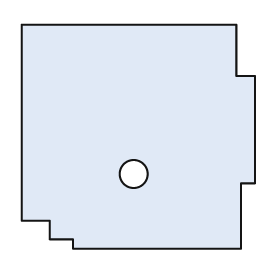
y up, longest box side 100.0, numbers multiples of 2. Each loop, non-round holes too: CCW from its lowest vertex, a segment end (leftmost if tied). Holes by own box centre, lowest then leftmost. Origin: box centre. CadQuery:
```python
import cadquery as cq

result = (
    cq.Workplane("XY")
    .moveTo(-28.0, -48.0)
    .lineTo(44.0, -48.0)
    .lineTo(44.0, -20.0)
    .lineTo(50.0, -20.0)
    .lineTo(50.0, 26.0)
    .lineTo(42.0, 26.0)
    .lineTo(42.0, 48.0)
    .lineTo(-50.0, 48.0)
    .lineTo(-50.0, -36.0)
    .lineTo(-38.0, -36.0)
    .lineTo(-38.0, -44.0)
    .lineTo(-28.0, -44.0)
    .close()
    .moveTo(-2.0, -16.0)
    .circle(6.0)
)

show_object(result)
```